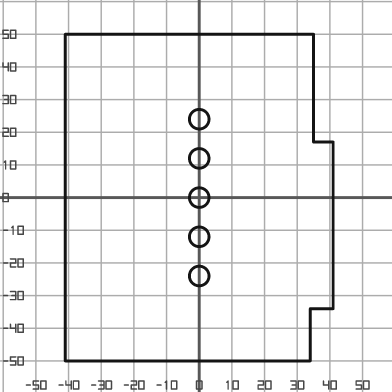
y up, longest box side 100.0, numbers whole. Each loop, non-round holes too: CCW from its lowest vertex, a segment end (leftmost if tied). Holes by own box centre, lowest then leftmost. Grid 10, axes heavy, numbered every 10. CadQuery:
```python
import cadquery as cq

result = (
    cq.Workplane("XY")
    .moveTo(-41.0, -50.0)
    .lineTo(34.0, -50.0)
    .lineTo(34.0, -34.0)
    .lineTo(41.0, -34.0)
    .lineTo(41.0, 17.0)
    .lineTo(35.0, 17.0)
    .lineTo(35.0, 50.0)
    .lineTo(-41.0, 50.0)
    .close()
    .moveTo(0.0, -24.0)
    .circle(3.0)
    .moveTo(0.0, -12.0)
    .circle(3.0)
    .moveTo(0.0, 0.0)
    .circle(3.0)
    .moveTo(0.0, 12.0)
    .circle(3.0)
    .moveTo(0.0, 24.0)
    .circle(3.0)
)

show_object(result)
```